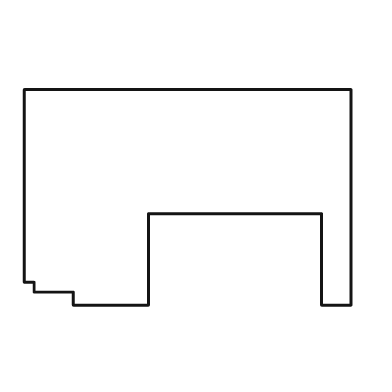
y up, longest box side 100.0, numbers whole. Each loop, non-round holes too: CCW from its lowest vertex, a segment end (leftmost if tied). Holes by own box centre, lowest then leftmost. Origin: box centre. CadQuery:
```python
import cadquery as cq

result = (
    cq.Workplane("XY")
    .moveTo(-35.0, -33.0)
    .lineTo(-12.0, -33.0)
    .lineTo(-12.0, -5.0)
    .lineTo(41.0, -5.0)
    .lineTo(41.0, -33.0)
    .lineTo(50.0, -33.0)
    .lineTo(50.0, 33.0)
    .lineTo(-50.0, 33.0)
    .lineTo(-50.0, -26.0)
    .lineTo(-47.0, -26.0)
    .lineTo(-47.0, -29.0)
    .lineTo(-35.0, -29.0)
    .close()
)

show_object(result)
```